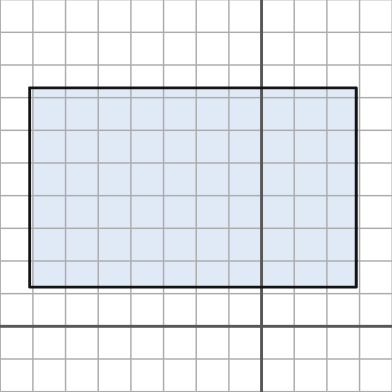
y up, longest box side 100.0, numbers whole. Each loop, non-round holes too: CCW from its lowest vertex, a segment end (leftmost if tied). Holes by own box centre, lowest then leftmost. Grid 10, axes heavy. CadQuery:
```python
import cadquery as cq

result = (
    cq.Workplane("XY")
    .moveTo(-71.0, 12.0)
    .lineTo(29.0, 12.0)
    .lineTo(29.0, 73.0)
    .lineTo(-71.0, 73.0)
    .close()
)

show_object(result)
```